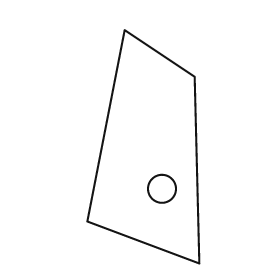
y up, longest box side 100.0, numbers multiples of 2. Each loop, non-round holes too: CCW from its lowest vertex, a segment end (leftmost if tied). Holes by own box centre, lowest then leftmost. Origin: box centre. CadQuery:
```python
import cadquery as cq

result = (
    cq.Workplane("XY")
    .moveTo(24.0, -50.0)
    .lineTo(22.0, 30.0)
    .lineTo(-8.0, 50.0)
    .lineTo(-24.0, -32.0)
    .close()
    .moveTo(8.0, -18.0)
    .circle(6.0)
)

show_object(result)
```